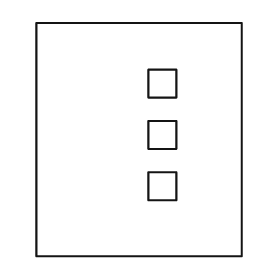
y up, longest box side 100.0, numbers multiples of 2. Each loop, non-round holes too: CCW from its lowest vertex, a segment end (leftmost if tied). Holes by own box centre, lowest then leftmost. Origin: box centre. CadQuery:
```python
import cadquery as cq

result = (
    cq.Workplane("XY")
    .moveTo(-44.0, -50.0)
    .lineTo(44.0, -50.0)
    .lineTo(44.0, 50.0)
    .lineTo(-44.0, 50.0)
    .close()
    .moveTo(4.0, -26.0)
    .lineTo(16.0, -26.0)
    .lineTo(16.0, -14.0)
    .lineTo(4.0, -14.0)
    .close()
    .moveTo(4.0, -4.0)
    .lineTo(16.0, -4.0)
    .lineTo(16.0, 8.0)
    .lineTo(4.0, 8.0)
    .close()
    .moveTo(4.0, 18.0)
    .lineTo(16.0, 18.0)
    .lineTo(16.0, 30.0)
    .lineTo(4.0, 30.0)
    .close()
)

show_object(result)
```